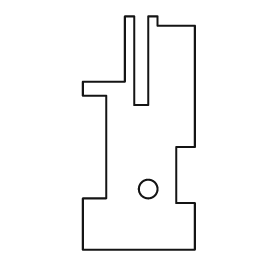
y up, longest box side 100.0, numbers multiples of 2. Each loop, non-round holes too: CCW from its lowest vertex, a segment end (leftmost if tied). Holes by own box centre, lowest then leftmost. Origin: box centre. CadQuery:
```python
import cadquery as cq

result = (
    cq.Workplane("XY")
    .moveTo(-24.0, -50.0)
    .lineTo(24.0, -50.0)
    .lineTo(24.0, -30.0)
    .lineTo(16.0, -30.0)
    .lineTo(16.0, -6.0)
    .lineTo(24.0, -6.0)
    .lineTo(24.0, 46.0)
    .lineTo(8.0, 46.0)
    .lineTo(8.0, 50.0)
    .lineTo(4.0, 50.0)
    .lineTo(4.0, 12.0)
    .lineTo(-2.0, 12.0)
    .lineTo(-2.0, 50.0)
    .lineTo(-6.0, 50.0)
    .lineTo(-6.0, 22.0)
    .lineTo(-24.0, 22.0)
    .lineTo(-24.0, 16.0)
    .lineTo(-14.0, 16.0)
    .lineTo(-14.0, -28.0)
    .lineTo(-24.0, -28.0)
    .close()
    .moveTo(4.0, -24.0)
    .circle(4.0)
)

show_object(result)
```